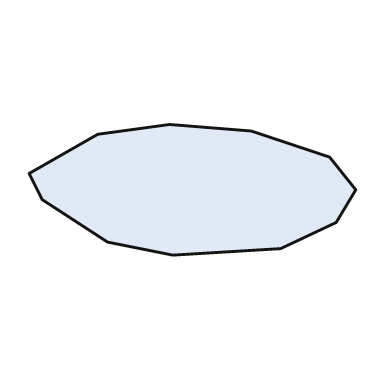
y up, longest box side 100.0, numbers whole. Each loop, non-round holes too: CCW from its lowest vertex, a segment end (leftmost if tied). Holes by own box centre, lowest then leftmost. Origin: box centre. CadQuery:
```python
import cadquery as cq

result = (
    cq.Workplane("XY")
    .moveTo(-6.0, -20.0)
    .lineTo(27.0, -18.0)
    .lineTo(44.0, -10.0)
    .lineTo(50.0, 0.0)
    .lineTo(42.0, 10.0)
    .lineTo(18.0, 18.0)
    .lineTo(-7.0, 20.0)
    .lineTo(-29.0, 17.0)
    .lineTo(-50.0, 5.0)
    .lineTo(-46.0, -3.0)
    .lineTo(-26.0, -16.0)
    .close()
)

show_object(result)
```